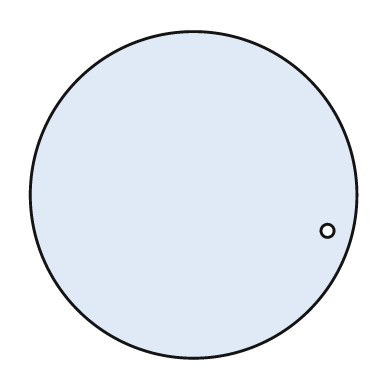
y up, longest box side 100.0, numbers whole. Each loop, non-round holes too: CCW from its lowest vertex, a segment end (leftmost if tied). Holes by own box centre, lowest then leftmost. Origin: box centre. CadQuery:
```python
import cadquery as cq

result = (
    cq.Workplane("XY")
    .moveTo(0.0, 0.0)
    .circle(50.0)
    .moveTo(41.0, -11.0)
    .circle(2.0)
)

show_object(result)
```